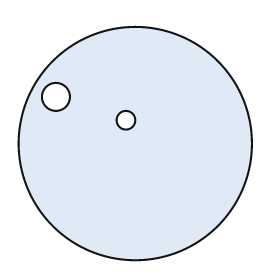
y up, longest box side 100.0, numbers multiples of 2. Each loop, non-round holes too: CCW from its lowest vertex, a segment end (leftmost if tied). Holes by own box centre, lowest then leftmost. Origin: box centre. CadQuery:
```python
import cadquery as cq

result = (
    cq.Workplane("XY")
    .moveTo(0.0, 0.0)
    .circle(50.0)
    .moveTo(-4.0, 10.0)
    .circle(4.0)
    .moveTo(-34.0, 20.0)
    .circle(6.0)
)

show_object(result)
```